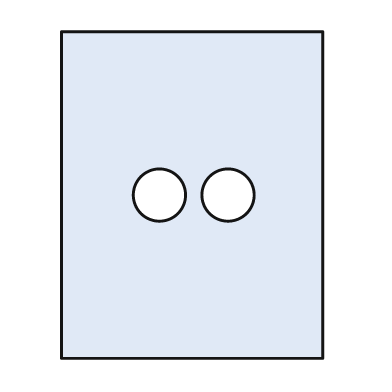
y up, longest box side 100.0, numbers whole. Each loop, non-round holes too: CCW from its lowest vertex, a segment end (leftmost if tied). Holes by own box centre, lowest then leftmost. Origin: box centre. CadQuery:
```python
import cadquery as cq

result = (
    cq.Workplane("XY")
    .moveTo(-40.0, -50.0)
    .lineTo(40.0, -50.0)
    .lineTo(40.0, 50.0)
    .lineTo(-40.0, 50.0)
    .close()
    .moveTo(-10.0, 0.0)
    .circle(8.0)
    .moveTo(11.0, 0.0)
    .circle(8.0)
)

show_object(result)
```